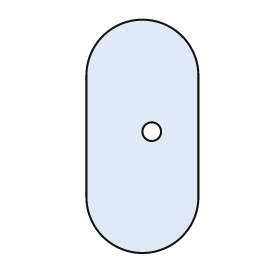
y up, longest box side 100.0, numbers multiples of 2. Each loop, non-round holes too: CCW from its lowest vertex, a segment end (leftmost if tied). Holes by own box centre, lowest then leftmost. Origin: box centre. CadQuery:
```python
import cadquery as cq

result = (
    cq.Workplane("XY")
    .moveTo(-24.0, -26.0)
    .threePointArc((0.0, -50.0), (24.0, -26.0))
    .lineTo(24.0, 26.0)
    .threePointArc((0.0, 50.0), (-24.0, 26.0))
    .close()
    .moveTo(4.0, 2.0)
    .circle(4.0)
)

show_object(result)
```